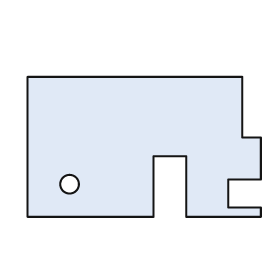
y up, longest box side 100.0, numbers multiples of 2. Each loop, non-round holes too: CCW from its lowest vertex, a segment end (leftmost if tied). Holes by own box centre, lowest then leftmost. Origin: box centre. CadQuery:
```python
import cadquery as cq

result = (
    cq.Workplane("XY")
    .moveTo(-50.0, -30.0)
    .lineTo(4.0, -30.0)
    .lineTo(4.0, -4.0)
    .lineTo(18.0, -4.0)
    .lineTo(18.0, -30.0)
    .lineTo(50.0, -30.0)
    .lineTo(50.0, -26.0)
    .lineTo(36.0, -26.0)
    .lineTo(36.0, -14.0)
    .lineTo(50.0, -14.0)
    .lineTo(50.0, 4.0)
    .lineTo(42.0, 4.0)
    .lineTo(42.0, 30.0)
    .lineTo(-50.0, 30.0)
    .close()
    .moveTo(-32.0, -16.0)
    .circle(4.0)
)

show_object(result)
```